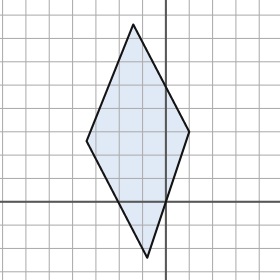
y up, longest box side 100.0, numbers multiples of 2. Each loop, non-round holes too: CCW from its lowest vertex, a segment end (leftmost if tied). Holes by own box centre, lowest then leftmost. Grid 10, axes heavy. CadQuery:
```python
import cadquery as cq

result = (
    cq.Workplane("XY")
    .moveTo(-8.0, -24.0)
    .lineTo(10.0, 30.0)
    .lineTo(-14.0, 76.0)
    .lineTo(-34.0, 26.0)
    .close()
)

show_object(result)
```